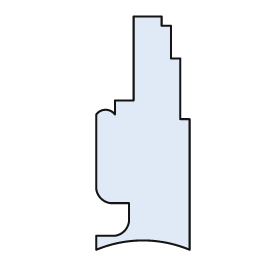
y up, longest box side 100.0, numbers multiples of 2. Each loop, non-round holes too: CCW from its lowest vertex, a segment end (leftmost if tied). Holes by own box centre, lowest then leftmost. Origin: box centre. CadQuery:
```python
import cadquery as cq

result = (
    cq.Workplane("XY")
    .moveTo(-20.0, -50.0)
    .threePointArc((0.0, -46.0), (20.0, -50.0))
    .lineTo(20.0, 6.0)
    .lineTo(16.0, 6.0)
    .lineTo(16.0, 32.0)
    .lineTo(12.0, 32.0)
    .lineTo(12.0, 46.0)
    .lineTo(8.0, 46.0)
    .lineTo(8.0, 50.0)
    .lineTo(-4.0, 50.0)
    .lineTo(-4.0, 14.0)
    .lineTo(-12.0, 14.0)
    .lineTo(-12.0, 8.0)
    .threePointArc((-16.0, 10.0), (-20.0, 8.0))
    .lineTo(-20.0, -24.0)
    .threePointArc((-18.0, -28.0), (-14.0, -30.0))
    .lineTo(-6.0, -30.0)
    .lineTo(-6.0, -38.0)
    .threePointArc((-8.0, -42.0), (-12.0, -44.0))
    .lineTo(-20.0, -44.0)
    .close()
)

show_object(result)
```